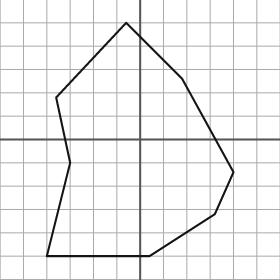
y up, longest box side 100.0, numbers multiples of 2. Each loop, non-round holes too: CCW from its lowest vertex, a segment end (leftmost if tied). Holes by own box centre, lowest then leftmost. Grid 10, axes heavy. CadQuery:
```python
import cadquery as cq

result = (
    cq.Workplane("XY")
    .moveTo(-40.0, -50.0)
    .lineTo(4.0, -50.0)
    .lineTo(32.0, -32.0)
    .lineTo(40.0, -14.0)
    .lineTo(18.0, 26.0)
    .lineTo(-6.0, 50.0)
    .lineTo(-36.0, 18.0)
    .lineTo(-30.0, -10.0)
    .close()
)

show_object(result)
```